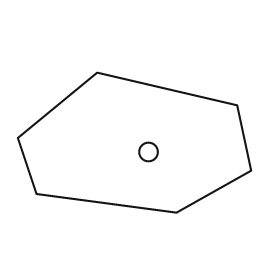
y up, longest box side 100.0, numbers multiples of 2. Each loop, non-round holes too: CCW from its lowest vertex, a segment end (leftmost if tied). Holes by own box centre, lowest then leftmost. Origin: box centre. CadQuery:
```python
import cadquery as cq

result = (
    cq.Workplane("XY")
    .moveTo(18.0, -30.0)
    .lineTo(50.0, -12.0)
    .lineTo(44.0, 16.0)
    .lineTo(-16.0, 30.0)
    .lineTo(-50.0, 2.0)
    .lineTo(-42.0, -22.0)
    .close()
    .moveTo(6.0, -4.0)
    .circle(4.0)
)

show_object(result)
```